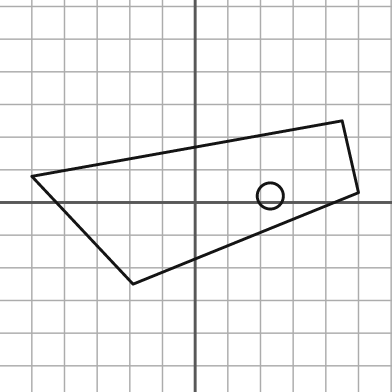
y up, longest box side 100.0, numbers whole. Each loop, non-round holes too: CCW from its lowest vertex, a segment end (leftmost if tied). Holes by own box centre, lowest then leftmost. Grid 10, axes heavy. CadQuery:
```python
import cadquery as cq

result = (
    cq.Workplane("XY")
    .moveTo(-19.0, -25.0)
    .lineTo(50.0, 3.0)
    .lineTo(45.0, 25.0)
    .lineTo(-50.0, 8.0)
    .close()
    .moveTo(23.0, 2.0)
    .circle(4.0)
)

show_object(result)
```